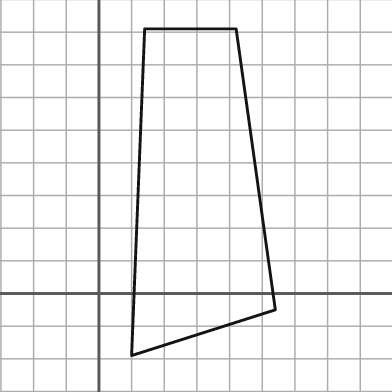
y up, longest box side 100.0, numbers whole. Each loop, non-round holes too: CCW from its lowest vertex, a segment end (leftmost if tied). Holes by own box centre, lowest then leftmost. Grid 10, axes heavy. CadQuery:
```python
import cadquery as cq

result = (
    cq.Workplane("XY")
    .moveTo(10.0, -19.0)
    .lineTo(54.0, -5.0)
    .lineTo(42.0, 81.0)
    .lineTo(14.0, 81.0)
    .close()
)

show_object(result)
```